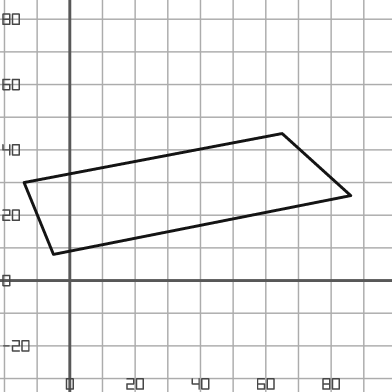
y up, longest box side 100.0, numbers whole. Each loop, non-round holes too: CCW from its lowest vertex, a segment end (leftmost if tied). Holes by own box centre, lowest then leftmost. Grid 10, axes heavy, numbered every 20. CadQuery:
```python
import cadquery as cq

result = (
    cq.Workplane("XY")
    .moveTo(-5.0, 8.0)
    .lineTo(86.0, 26.0)
    .lineTo(65.0, 45.0)
    .lineTo(-14.0, 30.0)
    .close()
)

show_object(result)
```